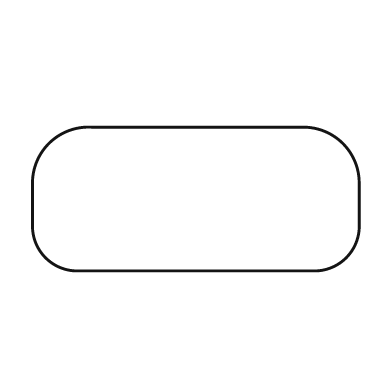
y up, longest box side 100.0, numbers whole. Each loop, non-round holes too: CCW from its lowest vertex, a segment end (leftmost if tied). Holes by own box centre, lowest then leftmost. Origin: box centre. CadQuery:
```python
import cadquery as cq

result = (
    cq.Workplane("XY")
    .moveTo(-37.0, -22.0)
    .lineTo(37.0, -22.0)
    .threePointArc((46.0, -18.0), (50.0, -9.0))
    .lineTo(50.0, 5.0)
    .threePointArc((45.0, 17.0), (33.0, 22.0))
    .lineTo(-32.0, 22.0)
    .threePointArc((-45.0, 17.0), (-50.0, 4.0))
    .lineTo(-50.0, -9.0)
    .threePointArc((-46.0, -18.0), (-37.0, -22.0))
    .close()
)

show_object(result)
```